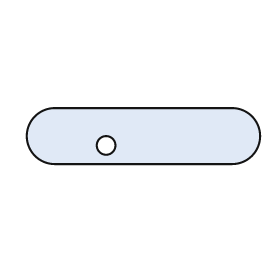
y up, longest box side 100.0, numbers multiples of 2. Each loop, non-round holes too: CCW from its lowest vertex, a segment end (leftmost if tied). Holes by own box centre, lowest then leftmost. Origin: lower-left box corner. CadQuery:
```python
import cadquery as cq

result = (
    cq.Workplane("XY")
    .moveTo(12.0, 0.0)
    .lineTo(88.0, 0.0)
    .threePointArc((100.0, 12.0), (88.0, 24.0))
    .lineTo(12.0, 24.0)
    .threePointArc((0.0, 12.0), (12.0, 0.0))
    .close()
    .moveTo(34.0, 8.0)
    .circle(4.0)
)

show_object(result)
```